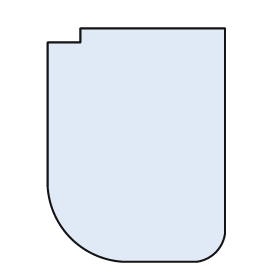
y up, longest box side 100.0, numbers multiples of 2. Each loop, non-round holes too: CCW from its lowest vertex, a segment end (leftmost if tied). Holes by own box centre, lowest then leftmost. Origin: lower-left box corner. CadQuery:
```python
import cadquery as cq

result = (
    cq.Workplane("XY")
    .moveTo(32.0, 0.0)
    .lineTo(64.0, 0.0)
    .threePointArc((72.0, 4.0), (76.0, 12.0))
    .lineTo(76.0, 100.0)
    .lineTo(14.0, 100.0)
    .lineTo(14.0, 94.0)
    .lineTo(0.0, 94.0)
    .lineTo(0.0, 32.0)
    .threePointArc((10.0, 10.0), (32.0, 0.0))
    .close()
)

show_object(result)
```